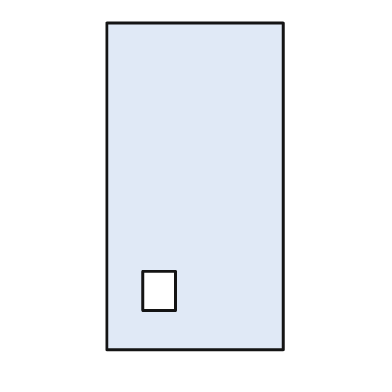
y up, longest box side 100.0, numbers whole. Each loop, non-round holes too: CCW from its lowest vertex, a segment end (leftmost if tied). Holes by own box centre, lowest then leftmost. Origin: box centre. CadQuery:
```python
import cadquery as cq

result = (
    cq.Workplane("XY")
    .moveTo(-27.0, -50.0)
    .lineTo(27.0, -50.0)
    .lineTo(27.0, 50.0)
    .lineTo(-27.0, 50.0)
    .close()
    .moveTo(-16.0, -38.0)
    .lineTo(-6.0, -38.0)
    .lineTo(-6.0, -26.0)
    .lineTo(-16.0, -26.0)
    .close()
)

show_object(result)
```